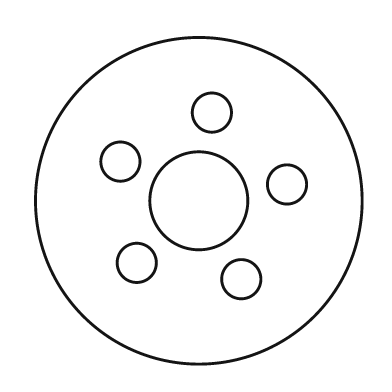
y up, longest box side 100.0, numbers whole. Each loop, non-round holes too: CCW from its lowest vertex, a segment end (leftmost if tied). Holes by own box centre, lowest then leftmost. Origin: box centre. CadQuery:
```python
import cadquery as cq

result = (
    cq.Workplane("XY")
    .moveTo(0.0, 0.0)
    .circle(50.0)
    .moveTo(13.0, -24.0)
    .circle(6.0)
    .moveTo(-19.0, -19.0)
    .circle(6.0)
    .moveTo(0.0, 0.0)
    .circle(15.0)
    .moveTo(27.0, 5.0)
    .circle(6.0)
    .moveTo(-24.0, 12.0)
    .circle(6.0)
    .moveTo(4.0, 27.0)
    .circle(6.0)
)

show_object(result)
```